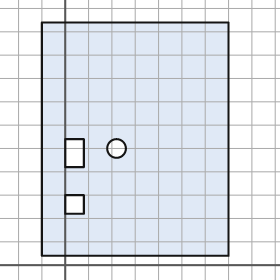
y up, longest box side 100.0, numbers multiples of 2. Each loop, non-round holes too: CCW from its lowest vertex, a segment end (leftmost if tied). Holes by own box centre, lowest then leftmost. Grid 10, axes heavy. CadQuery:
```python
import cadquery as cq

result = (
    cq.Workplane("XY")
    .moveTo(-10.0, 4.0)
    .lineTo(70.0, 4.0)
    .lineTo(70.0, 104.0)
    .lineTo(-10.0, 104.0)
    .close()
    .moveTo(0.0, 22.0)
    .lineTo(8.0, 22.0)
    .lineTo(8.0, 30.0)
    .lineTo(0.0, 30.0)
    .close()
    .moveTo(0.0, 42.0)
    .lineTo(8.0, 42.0)
    .lineTo(8.0, 54.0)
    .lineTo(0.0, 54.0)
    .close()
    .moveTo(22.0, 50.0)
    .circle(4.0)
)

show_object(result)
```